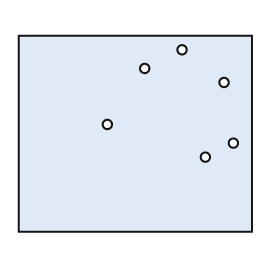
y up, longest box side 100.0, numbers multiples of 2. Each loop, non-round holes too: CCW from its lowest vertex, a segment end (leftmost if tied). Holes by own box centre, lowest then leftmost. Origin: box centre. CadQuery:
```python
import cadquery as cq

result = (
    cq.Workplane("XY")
    .moveTo(-50.0, -42.0)
    .lineTo(50.0, -42.0)
    .lineTo(50.0, 42.0)
    .lineTo(-50.0, 42.0)
    .close()
    .moveTo(30.0, -10.0)
    .circle(2.0)
    .moveTo(42.0, -4.0)
    .circle(2.0)
    .moveTo(-12.0, 4.0)
    .circle(2.0)
    .moveTo(38.0, 22.0)
    .circle(2.0)
    .moveTo(4.0, 28.0)
    .circle(2.0)
    .moveTo(20.0, 36.0)
    .circle(2.0)
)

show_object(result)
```